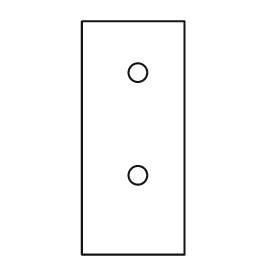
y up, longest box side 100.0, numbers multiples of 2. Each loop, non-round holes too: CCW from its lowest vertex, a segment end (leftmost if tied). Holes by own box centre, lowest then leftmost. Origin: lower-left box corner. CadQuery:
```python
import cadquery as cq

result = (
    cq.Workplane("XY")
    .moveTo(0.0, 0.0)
    .lineTo(44.0, 0.0)
    .lineTo(44.0, 100.0)
    .lineTo(0.0, 100.0)
    .close()
    .moveTo(24.0, 34.0)
    .circle(4.0)
    .moveTo(24.0, 78.0)
    .circle(4.0)
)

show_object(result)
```